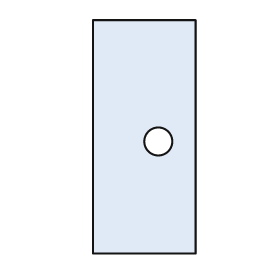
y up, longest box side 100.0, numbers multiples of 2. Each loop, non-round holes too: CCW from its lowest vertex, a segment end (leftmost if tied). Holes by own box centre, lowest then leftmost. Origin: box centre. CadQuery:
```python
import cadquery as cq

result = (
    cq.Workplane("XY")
    .moveTo(-22.0, -50.0)
    .lineTo(22.0, -50.0)
    .lineTo(22.0, 50.0)
    .lineTo(-22.0, 50.0)
    .close()
    .moveTo(6.0, -2.0)
    .circle(6.0)
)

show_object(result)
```